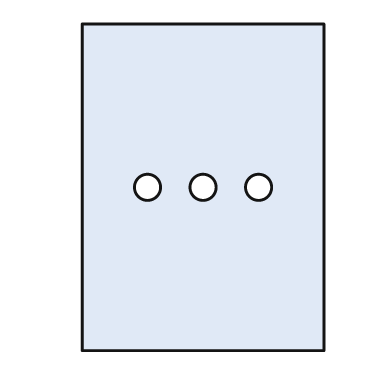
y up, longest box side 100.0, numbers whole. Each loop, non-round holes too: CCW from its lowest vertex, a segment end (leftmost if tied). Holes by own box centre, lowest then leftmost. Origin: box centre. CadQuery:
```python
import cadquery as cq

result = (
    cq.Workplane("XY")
    .moveTo(-37.0, -50.0)
    .lineTo(37.0, -50.0)
    .lineTo(37.0, 50.0)
    .lineTo(-37.0, 50.0)
    .close()
    .moveTo(-17.0, 0.0)
    .circle(4.0)
    .moveTo(0.0, 0.0)
    .circle(4.0)
    .moveTo(17.0, 0.0)
    .circle(4.0)
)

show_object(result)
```